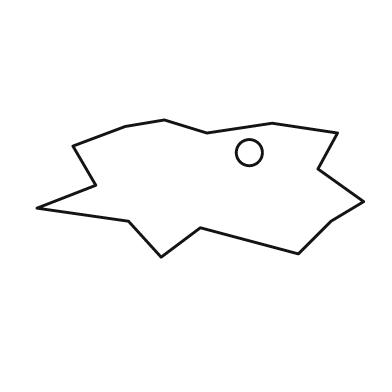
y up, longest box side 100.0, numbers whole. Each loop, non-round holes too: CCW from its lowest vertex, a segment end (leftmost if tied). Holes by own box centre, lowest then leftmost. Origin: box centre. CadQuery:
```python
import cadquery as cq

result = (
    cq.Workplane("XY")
    .moveTo(-12.0, -21.0)
    .lineTo(0.0, -12.0)
    .lineTo(30.0, -20.0)
    .lineTo(40.0, -10.0)
    .lineTo(50.0, -4.0)
    .lineTo(36.0, 6.0)
    .lineTo(42.0, 17.0)
    .lineTo(22.0, 20.0)
    .lineTo(2.0, 17.0)
    .lineTo(-11.0, 21.0)
    .lineTo(-23.0, 19.0)
    .lineTo(-39.0, 13.0)
    .lineTo(-32.0, 1.0)
    .lineTo(-50.0, -6.0)
    .lineTo(-22.0, -10.0)
    .close()
    .moveTo(15.0, 11.0)
    .circle(4.0)
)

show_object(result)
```